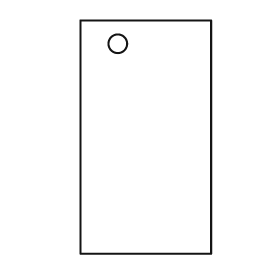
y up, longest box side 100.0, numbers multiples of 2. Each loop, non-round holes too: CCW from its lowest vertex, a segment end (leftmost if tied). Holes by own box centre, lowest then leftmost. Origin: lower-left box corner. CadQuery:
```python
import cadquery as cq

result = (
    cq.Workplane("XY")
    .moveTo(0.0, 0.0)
    .lineTo(56.0, 0.0)
    .lineTo(56.0, 100.0)
    .lineTo(0.0, 100.0)
    .close()
    .moveTo(16.0, 90.0)
    .circle(4.0)
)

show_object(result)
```